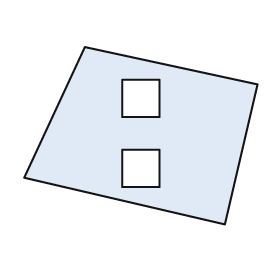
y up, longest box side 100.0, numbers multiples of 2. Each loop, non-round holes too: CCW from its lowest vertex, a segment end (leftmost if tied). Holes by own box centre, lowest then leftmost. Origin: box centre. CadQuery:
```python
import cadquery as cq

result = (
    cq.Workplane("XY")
    .moveTo(36.0, -38.0)
    .lineTo(50.0, 22.0)
    .lineTo(-24.0, 38.0)
    .lineTo(-50.0, -18.0)
    .close()
    .moveTo(-8.0, -22.0)
    .lineTo(8.0, -22.0)
    .lineTo(8.0, -6.0)
    .lineTo(-8.0, -6.0)
    .close()
    .moveTo(-8.0, 8.0)
    .lineTo(8.0, 8.0)
    .lineTo(8.0, 24.0)
    .lineTo(-8.0, 24.0)
    .close()
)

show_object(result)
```